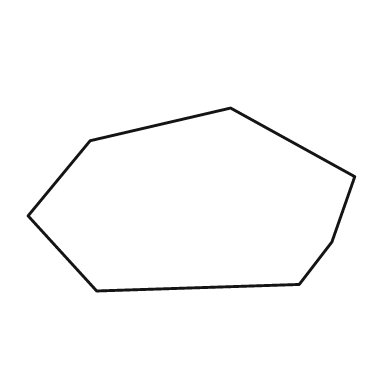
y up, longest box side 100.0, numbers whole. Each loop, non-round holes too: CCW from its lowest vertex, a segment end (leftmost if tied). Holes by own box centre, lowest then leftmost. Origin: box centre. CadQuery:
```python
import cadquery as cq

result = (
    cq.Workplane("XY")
    .moveTo(-29.0, -28.0)
    .lineTo(33.0, -26.0)
    .lineTo(43.0, -13.0)
    .lineTo(50.0, 7.0)
    .lineTo(12.0, 28.0)
    .lineTo(-31.0, 18.0)
    .lineTo(-50.0, -5.0)
    .close()
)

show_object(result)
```